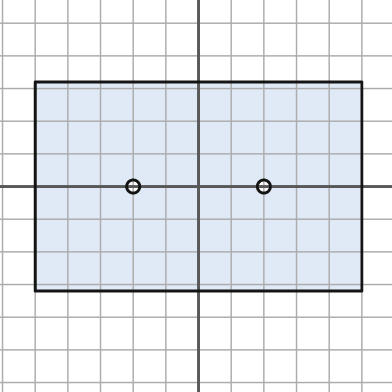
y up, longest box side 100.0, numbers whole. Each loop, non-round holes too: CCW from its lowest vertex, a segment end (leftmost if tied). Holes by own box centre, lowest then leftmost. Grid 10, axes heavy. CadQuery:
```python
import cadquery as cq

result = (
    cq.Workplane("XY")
    .moveTo(-50.0, -32.0)
    .lineTo(50.0, -32.0)
    .lineTo(50.0, 32.0)
    .lineTo(-50.0, 32.0)
    .close()
    .moveTo(-20.0, 0.0)
    .circle(2.0)
    .moveTo(20.0, 0.0)
    .circle(2.0)
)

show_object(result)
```